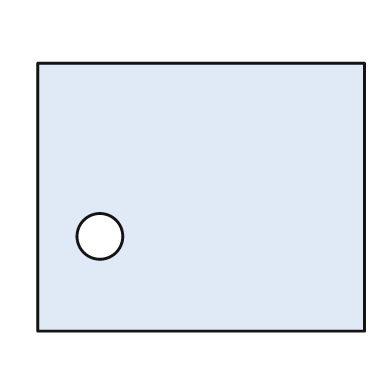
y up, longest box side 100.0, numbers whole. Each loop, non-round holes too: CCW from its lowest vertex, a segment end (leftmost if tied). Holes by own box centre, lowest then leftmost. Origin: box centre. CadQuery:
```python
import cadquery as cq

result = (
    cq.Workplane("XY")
    .moveTo(-50.0, -41.0)
    .lineTo(50.0, -41.0)
    .lineTo(50.0, 41.0)
    .lineTo(-50.0, 41.0)
    .close()
    .moveTo(-31.0, -12.0)
    .circle(7.0)
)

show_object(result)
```